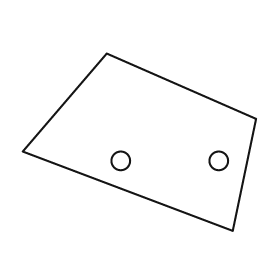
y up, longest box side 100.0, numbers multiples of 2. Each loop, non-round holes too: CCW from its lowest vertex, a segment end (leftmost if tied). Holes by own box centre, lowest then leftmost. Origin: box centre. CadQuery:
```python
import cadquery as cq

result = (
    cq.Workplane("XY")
    .moveTo(40.0, -38.0)
    .lineTo(50.0, 10.0)
    .lineTo(-14.0, 38.0)
    .lineTo(-50.0, -4.0)
    .close()
    .moveTo(-8.0, -8.0)
    .circle(4.0)
    .moveTo(34.0, -8.0)
    .circle(4.0)
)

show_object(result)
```